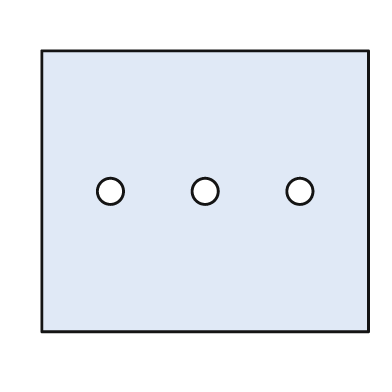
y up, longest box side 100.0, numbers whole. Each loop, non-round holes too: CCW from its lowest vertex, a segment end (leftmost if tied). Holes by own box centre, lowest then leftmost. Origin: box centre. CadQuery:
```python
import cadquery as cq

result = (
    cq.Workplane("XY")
    .moveTo(-50.0, -43.0)
    .lineTo(50.0, -43.0)
    .lineTo(50.0, 43.0)
    .lineTo(-50.0, 43.0)
    .close()
    .moveTo(-29.0, 0.0)
    .circle(4.0)
    .moveTo(0.0, 0.0)
    .circle(4.0)
    .moveTo(29.0, 0.0)
    .circle(4.0)
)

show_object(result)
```